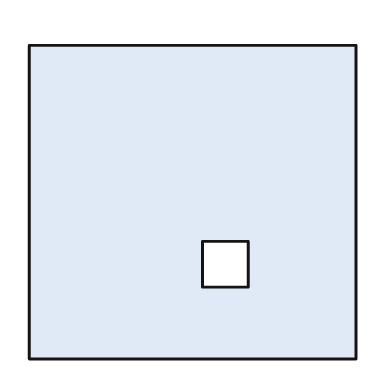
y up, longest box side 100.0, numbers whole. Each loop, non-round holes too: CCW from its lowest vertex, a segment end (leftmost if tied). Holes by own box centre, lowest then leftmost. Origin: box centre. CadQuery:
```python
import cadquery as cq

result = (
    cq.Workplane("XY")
    .moveTo(-50.0, -48.0)
    .lineTo(50.0, -48.0)
    .lineTo(50.0, 48.0)
    .lineTo(-50.0, 48.0)
    .close()
    .moveTo(3.0, -26.0)
    .lineTo(17.0, -26.0)
    .lineTo(17.0, -12.0)
    .lineTo(3.0, -12.0)
    .close()
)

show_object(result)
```